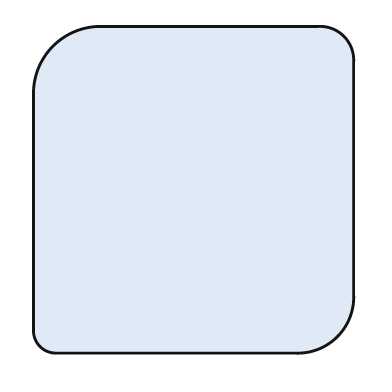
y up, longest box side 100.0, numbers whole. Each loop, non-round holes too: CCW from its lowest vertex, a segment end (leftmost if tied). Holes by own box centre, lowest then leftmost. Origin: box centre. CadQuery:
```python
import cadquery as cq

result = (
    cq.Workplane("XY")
    .moveTo(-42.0, -50.0)
    .lineTo(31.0, -50.0)
    .threePointArc((44.0, -45.0), (49.0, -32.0))
    .lineTo(49.0, 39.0)
    .threePointArc((46.0, 47.0), (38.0, 50.0))
    .lineTo(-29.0, 50.0)
    .threePointArc((-43.0, 44.0), (-49.0, 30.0))
    .lineTo(-49.0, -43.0)
    .threePointArc((-47.0, -48.0), (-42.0, -50.0))
    .close()
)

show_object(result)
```